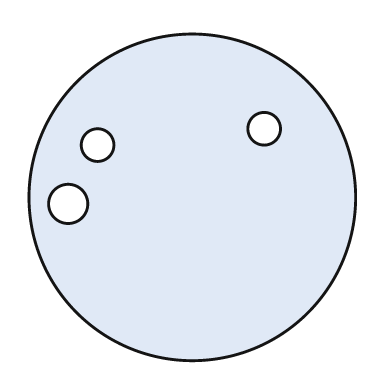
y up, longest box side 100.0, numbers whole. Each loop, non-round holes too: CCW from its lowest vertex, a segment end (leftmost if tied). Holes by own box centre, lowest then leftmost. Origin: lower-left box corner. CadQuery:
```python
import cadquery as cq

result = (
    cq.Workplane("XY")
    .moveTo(50.0, 50.0)
    .circle(50.0)
    .moveTo(12.0, 48.0)
    .circle(6.0)
    .moveTo(21.0, 66.0)
    .circle(5.0)
    .moveTo(72.0, 71.0)
    .circle(5.0)
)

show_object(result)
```